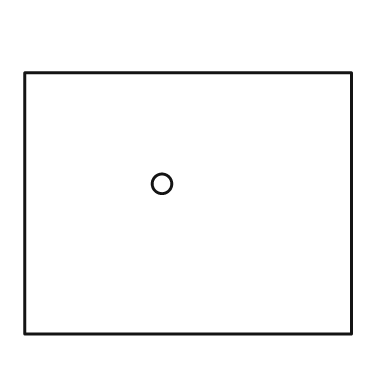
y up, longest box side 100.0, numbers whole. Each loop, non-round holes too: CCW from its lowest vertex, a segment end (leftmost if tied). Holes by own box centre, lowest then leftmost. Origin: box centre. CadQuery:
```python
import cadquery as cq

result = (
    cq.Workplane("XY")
    .moveTo(-50.0, -40.0)
    .lineTo(50.0, -40.0)
    .lineTo(50.0, 40.0)
    .lineTo(-50.0, 40.0)
    .close()
    .moveTo(-8.0, 6.0)
    .circle(3.0)
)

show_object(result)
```